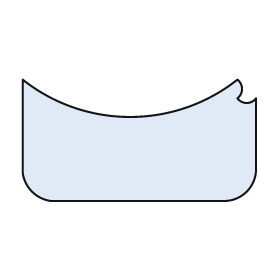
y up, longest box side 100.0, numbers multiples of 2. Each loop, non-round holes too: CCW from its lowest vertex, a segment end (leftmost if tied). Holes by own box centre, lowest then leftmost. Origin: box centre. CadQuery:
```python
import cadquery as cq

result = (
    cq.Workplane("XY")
    .moveTo(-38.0, -26.0)
    .lineTo(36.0, -26.0)
    .threePointArc((46.0, -22.0), (50.0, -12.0))
    .lineTo(50.0, 18.0)
    .threePointArc((46.0, 16.0), (42.0, 18.0))
    .threePointArc((44.0, 22.0), (42.0, 26.0))
    .threePointArc((-4.0, 10.0), (-50.0, 26.0))
    .lineTo(-50.0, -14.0)
    .threePointArc((-46.0, -22.0), (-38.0, -26.0))
    .close()
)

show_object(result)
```